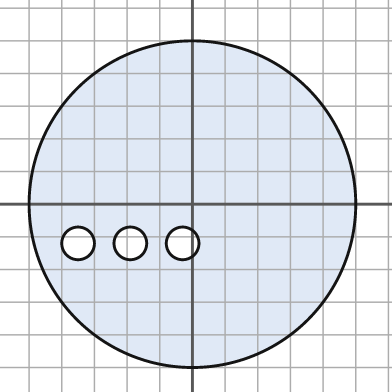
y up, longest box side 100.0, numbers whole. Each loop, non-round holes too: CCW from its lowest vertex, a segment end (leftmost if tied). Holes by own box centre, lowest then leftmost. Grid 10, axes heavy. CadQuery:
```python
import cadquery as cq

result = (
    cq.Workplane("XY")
    .moveTo(0.0, 0.0)
    .circle(50.0)
    .moveTo(-35.0, -12.0)
    .circle(5.0)
    .moveTo(-19.0, -12.0)
    .circle(5.0)
    .moveTo(-3.0, -12.0)
    .circle(5.0)
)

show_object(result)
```